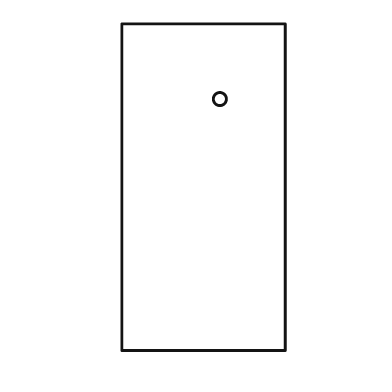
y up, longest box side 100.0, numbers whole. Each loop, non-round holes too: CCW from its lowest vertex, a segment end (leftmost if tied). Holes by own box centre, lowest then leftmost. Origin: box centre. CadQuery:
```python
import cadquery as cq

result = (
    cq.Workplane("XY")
    .moveTo(-25.0, -50.0)
    .lineTo(25.0, -50.0)
    .lineTo(25.0, 50.0)
    .lineTo(-25.0, 50.0)
    .close()
    .moveTo(5.0, 27.0)
    .circle(2.0)
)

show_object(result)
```